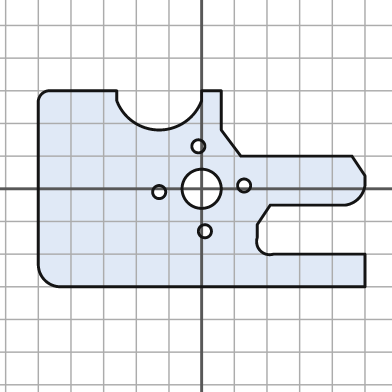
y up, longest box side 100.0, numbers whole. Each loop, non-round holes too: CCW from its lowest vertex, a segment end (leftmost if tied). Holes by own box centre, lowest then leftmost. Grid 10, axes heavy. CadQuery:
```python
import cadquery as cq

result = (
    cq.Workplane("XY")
    .moveTo(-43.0, -30.0)
    .lineTo(50.0, -30.0)
    .lineTo(50.0, -20.0)
    .lineTo(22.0, -20.0)
    .threePointArc((18.0, -19.0), (17.0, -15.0))
    .lineTo(17.0, -11.0)
    .lineTo(21.0, -5.0)
    .lineTo(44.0, -5.0)
    .threePointArc((48.0, -3.0), (50.0, 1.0))
    .lineTo(50.0, 4.0)
    .lineTo(46.0, 10.0)
    .lineTo(12.0, 10.0)
    .lineTo(6.0, 18.0)
    .lineTo(6.0, 30.0)
    .lineTo(0.0, 30.0)
    .lineTo(0.0, 27.0)
    .threePointArc((-13.0, 18.0), (-26.0, 27.0))
    .lineTo(-26.0, 30.0)
    .lineTo(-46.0, 30.0)
    .threePointArc((-49.0, 29.0), (-50.0, 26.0))
    .lineTo(-50.0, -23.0)
    .threePointArc((-48.0, -28.0), (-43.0, -30.0))
    .close()
    .moveTo(1.0, -13.0)
    .circle(2.0)
    .moveTo(-13.0, -1.0)
    .circle(2.0)
    .moveTo(0.0, 0.0)
    .circle(6.0)
    .moveTo(13.0, 1.0)
    .circle(2.0)
    .moveTo(-1.0, 13.0)
    .circle(2.0)
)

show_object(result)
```